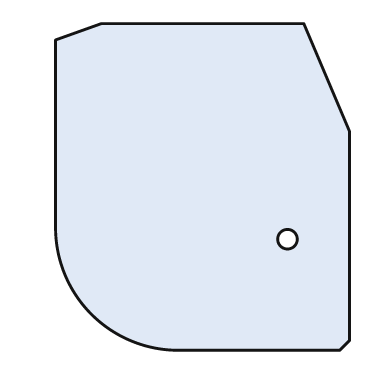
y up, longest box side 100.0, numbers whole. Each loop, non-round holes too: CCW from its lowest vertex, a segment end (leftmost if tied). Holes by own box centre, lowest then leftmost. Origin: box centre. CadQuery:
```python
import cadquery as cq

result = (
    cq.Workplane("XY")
    .moveTo(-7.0, -50.0)
    .lineTo(42.0, -50.0)
    .lineTo(45.0, -47.0)
    .lineTo(45.0, 17.0)
    .lineTo(31.0, 50.0)
    .lineTo(-31.0, 50.0)
    .lineTo(-45.0, 45.0)
    .lineTo(-45.0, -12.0)
    .threePointArc((-34.0, -39.0), (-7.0, -50.0))
    .close()
    .moveTo(26.0, -16.0)
    .circle(3.0)
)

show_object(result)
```